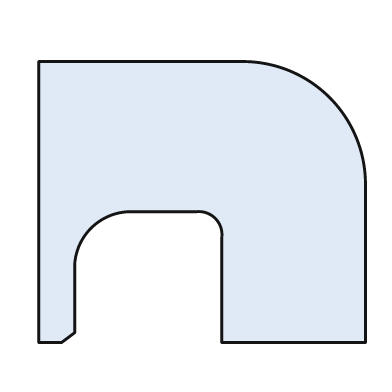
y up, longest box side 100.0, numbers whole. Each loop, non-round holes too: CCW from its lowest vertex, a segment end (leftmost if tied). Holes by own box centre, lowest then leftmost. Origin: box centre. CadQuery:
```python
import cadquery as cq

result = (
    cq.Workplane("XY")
    .moveTo(-50.0, -43.0)
    .lineTo(-43.0, -43.0)
    .lineTo(-39.0, -40.0)
    .lineTo(-39.0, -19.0)
    .threePointArc((-34.0, -8.0), (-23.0, -3.0))
    .lineTo(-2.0, -3.0)
    .threePointArc((4.0, -5.0), (6.0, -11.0))
    .lineTo(6.0, -43.0)
    .lineTo(50.0, -43.0)
    .lineTo(50.0, 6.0)
    .threePointArc((39.0, 32.0), (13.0, 43.0))
    .lineTo(-50.0, 43.0)
    .close()
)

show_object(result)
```